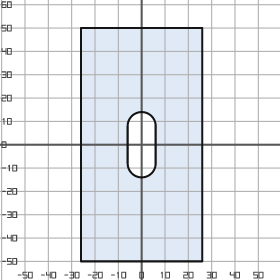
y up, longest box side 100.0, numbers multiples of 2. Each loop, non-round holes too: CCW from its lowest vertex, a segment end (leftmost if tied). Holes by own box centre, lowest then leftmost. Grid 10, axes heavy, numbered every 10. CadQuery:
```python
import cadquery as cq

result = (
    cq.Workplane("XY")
    .moveTo(-26.0, -50.0)
    .lineTo(26.0, -50.0)
    .lineTo(26.0, 50.0)
    .lineTo(-26.0, 50.0)
    .close()
    .moveTo(-6.0, -8.0)
    .threePointArc((0.0, -14.0), (6.0, -8.0))
    .lineTo(6.0, 8.0)
    .threePointArc((0.0, 14.0), (-6.0, 8.0))
    .close()
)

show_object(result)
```